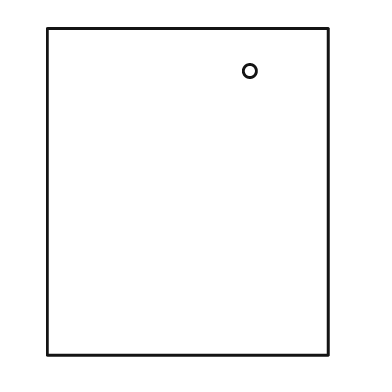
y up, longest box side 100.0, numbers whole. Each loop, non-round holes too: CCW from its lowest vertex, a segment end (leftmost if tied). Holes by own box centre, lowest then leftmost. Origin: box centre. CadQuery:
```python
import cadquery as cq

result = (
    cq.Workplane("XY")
    .moveTo(-43.0, -50.0)
    .lineTo(43.0, -50.0)
    .lineTo(43.0, 50.0)
    .lineTo(-43.0, 50.0)
    .close()
    .moveTo(19.0, 37.0)
    .circle(2.0)
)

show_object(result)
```